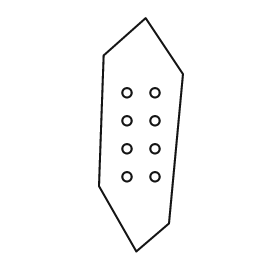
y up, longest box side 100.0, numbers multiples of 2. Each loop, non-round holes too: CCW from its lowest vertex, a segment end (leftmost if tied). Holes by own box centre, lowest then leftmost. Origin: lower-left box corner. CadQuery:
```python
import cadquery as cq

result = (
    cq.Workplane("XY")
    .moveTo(16.0, 0.0)
    .lineTo(30.0, 12.0)
    .lineTo(36.0, 76.0)
    .lineTo(20.0, 100.0)
    .lineTo(2.0, 84.0)
    .lineTo(0.0, 28.0)
    .close()
    .moveTo(12.0, 32.0)
    .circle(2.0)
    .moveTo(24.0, 32.0)
    .circle(2.0)
    .moveTo(12.0, 44.0)
    .circle(2.0)
    .moveTo(24.0, 44.0)
    .circle(2.0)
    .moveTo(12.0, 56.0)
    .circle(2.0)
    .moveTo(24.0, 56.0)
    .circle(2.0)
    .moveTo(12.0, 68.0)
    .circle(2.0)
    .moveTo(24.0, 68.0)
    .circle(2.0)
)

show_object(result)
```